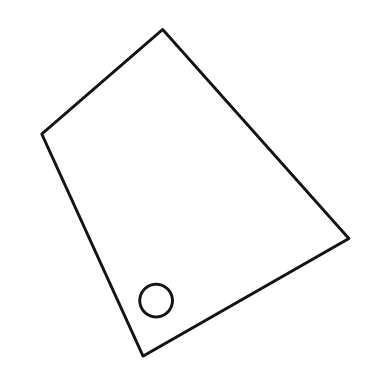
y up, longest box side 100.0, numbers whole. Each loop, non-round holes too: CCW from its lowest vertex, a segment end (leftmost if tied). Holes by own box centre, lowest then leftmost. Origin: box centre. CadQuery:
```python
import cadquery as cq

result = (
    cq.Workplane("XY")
    .moveTo(-16.0, -50.0)
    .lineTo(47.0, -14.0)
    .lineTo(-10.0, 50.0)
    .lineTo(-47.0, 18.0)
    .close()
    .moveTo(-12.0, -33.0)
    .circle(5.0)
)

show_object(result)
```